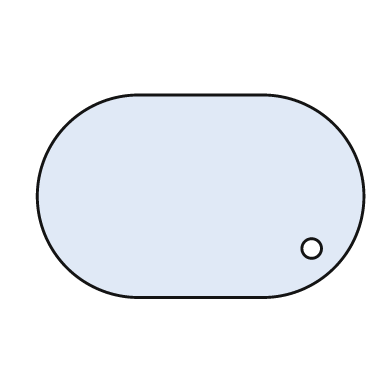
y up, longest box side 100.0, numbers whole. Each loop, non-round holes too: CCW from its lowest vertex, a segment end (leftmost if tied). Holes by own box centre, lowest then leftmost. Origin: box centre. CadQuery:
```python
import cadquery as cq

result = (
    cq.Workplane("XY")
    .moveTo(-19.0, -31.0)
    .lineTo(19.0, -31.0)
    .threePointArc((50.0, 0.0), (19.0, 31.0))
    .lineTo(-19.0, 31.0)
    .threePointArc((-50.0, 0.0), (-19.0, -31.0))
    .close()
    .moveTo(34.0, -16.0)
    .circle(3.0)
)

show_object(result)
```